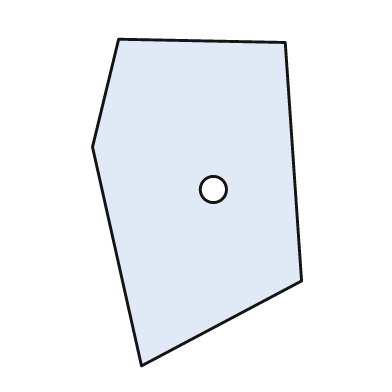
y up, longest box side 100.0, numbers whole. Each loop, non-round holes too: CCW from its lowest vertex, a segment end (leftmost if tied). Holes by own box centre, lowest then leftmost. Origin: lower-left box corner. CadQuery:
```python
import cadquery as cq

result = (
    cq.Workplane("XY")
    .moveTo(15.0, 0.0)
    .lineTo(64.0, 26.0)
    .lineTo(59.0, 99.0)
    .lineTo(8.0, 100.0)
    .lineTo(0.0, 67.0)
    .close()
    .moveTo(37.0, 54.0)
    .circle(4.0)
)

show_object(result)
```